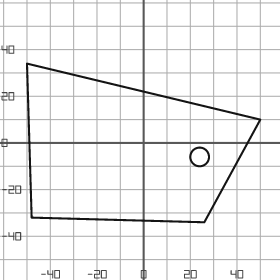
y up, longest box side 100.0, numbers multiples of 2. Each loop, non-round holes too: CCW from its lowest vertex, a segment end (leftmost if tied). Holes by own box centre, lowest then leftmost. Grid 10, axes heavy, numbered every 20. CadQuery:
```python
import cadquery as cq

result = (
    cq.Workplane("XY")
    .moveTo(26.0, -34.0)
    .lineTo(50.0, 10.0)
    .lineTo(-50.0, 34.0)
    .lineTo(-48.0, -32.0)
    .close()
    .moveTo(24.0, -6.0)
    .circle(4.0)
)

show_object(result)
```